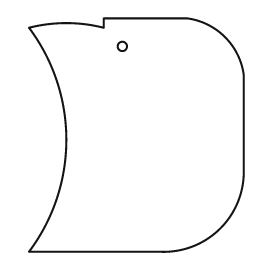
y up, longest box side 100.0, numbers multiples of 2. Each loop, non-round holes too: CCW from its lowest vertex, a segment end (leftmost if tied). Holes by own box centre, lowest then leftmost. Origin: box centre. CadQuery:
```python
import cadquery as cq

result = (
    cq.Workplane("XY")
    .moveTo(-46.0, -50.0)
    .lineTo(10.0, -50.0)
    .threePointArc((36.0, -40.0), (46.0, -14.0))
    .lineTo(46.0, 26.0)
    .threePointArc((38.0, 42.0), (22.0, 50.0))
    .lineTo(-14.0, 50.0)
    .lineTo(-14.0, 46.0)
    .threePointArc((-30.0, 48.0), (-46.0, 46.0))
    .threePointArc((-30.0, -2.0), (-46.0, -50.0))
    .close()
    .moveTo(-6.0, 38.0)
    .circle(2.0)
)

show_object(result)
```